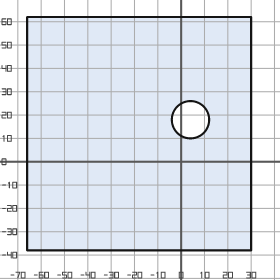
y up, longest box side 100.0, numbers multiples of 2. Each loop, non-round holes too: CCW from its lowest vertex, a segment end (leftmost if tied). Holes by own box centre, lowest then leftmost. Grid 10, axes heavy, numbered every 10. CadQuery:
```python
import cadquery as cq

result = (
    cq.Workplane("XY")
    .moveTo(-66.0, -38.0)
    .lineTo(30.0, -38.0)
    .lineTo(30.0, 62.0)
    .lineTo(-66.0, 62.0)
    .close()
    .moveTo(4.0, 18.0)
    .circle(8.0)
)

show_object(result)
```